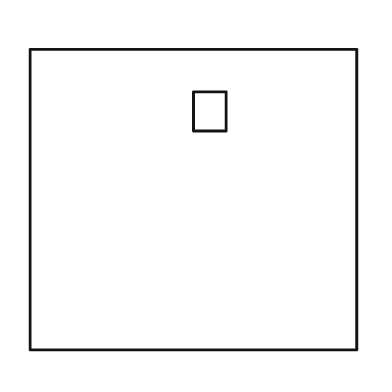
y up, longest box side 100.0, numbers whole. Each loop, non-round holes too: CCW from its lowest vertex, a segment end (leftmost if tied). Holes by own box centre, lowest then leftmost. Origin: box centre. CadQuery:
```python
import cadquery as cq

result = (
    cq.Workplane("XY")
    .moveTo(-50.0, -46.0)
    .lineTo(50.0, -46.0)
    .lineTo(50.0, 46.0)
    .lineTo(-50.0, 46.0)
    .close()
    .moveTo(0.0, 21.0)
    .lineTo(10.0, 21.0)
    .lineTo(10.0, 33.0)
    .lineTo(0.0, 33.0)
    .close()
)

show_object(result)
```